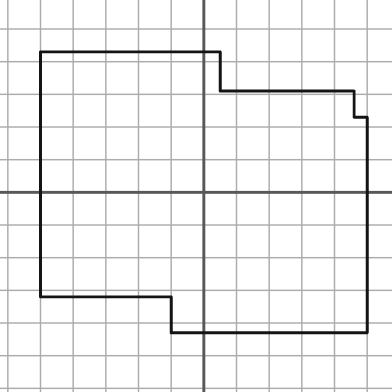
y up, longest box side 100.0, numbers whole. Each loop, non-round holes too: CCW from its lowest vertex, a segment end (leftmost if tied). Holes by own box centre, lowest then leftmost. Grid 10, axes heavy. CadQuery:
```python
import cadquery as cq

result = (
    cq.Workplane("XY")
    .moveTo(-10.0, -43.0)
    .lineTo(50.0, -43.0)
    .lineTo(50.0, 23.0)
    .lineTo(46.0, 23.0)
    .lineTo(46.0, 31.0)
    .lineTo(5.0, 31.0)
    .lineTo(5.0, 43.0)
    .lineTo(-50.0, 43.0)
    .lineTo(-50.0, -32.0)
    .lineTo(-10.0, -32.0)
    .close()
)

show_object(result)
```